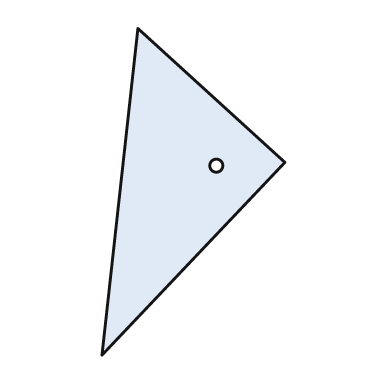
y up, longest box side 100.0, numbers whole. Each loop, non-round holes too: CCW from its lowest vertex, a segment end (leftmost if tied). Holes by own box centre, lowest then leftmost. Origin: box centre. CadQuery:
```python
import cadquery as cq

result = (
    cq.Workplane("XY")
    .moveTo(-28.0, -50.0)
    .lineTo(28.0, 9.0)
    .lineTo(-17.0, 50.0)
    .close()
    .moveTo(7.0, 8.0)
    .circle(2.0)
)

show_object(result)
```